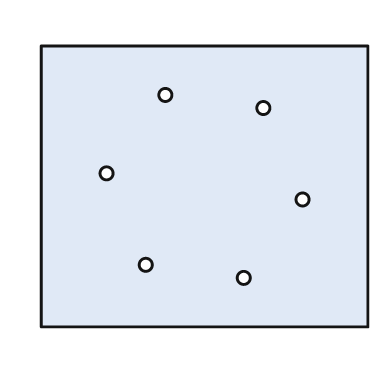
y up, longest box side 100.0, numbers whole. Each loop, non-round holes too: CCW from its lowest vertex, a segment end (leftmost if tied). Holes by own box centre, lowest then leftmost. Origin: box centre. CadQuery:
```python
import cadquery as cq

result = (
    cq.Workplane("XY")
    .moveTo(-50.0, -43.0)
    .lineTo(50.0, -43.0)
    .lineTo(50.0, 43.0)
    .lineTo(-50.0, 43.0)
    .close()
    .moveTo(12.0, -28.0)
    .circle(2.0)
    .moveTo(-18.0, -24.0)
    .circle(2.0)
    .moveTo(30.0, -4.0)
    .circle(2.0)
    .moveTo(-30.0, 4.0)
    .circle(2.0)
    .moveTo(18.0, 24.0)
    .circle(2.0)
    .moveTo(-12.0, 28.0)
    .circle(2.0)
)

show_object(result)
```